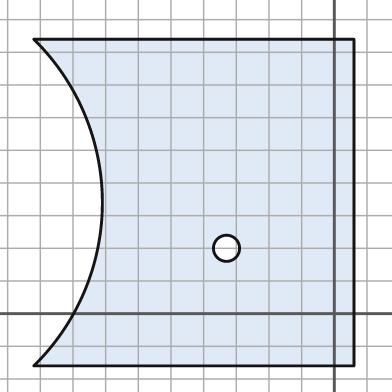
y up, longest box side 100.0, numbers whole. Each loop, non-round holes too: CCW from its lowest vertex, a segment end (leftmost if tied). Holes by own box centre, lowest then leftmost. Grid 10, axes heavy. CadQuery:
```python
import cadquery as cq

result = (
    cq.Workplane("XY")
    .moveTo(-92.0, -16.0)
    .lineTo(6.0, -16.0)
    .lineTo(6.0, 84.0)
    .lineTo(-92.0, 84.0)
    .threePointArc((-71.0, 34.0), (-92.0, -16.0))
    .close()
    .moveTo(-33.0, 20.0)
    .circle(4.0)
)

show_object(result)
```